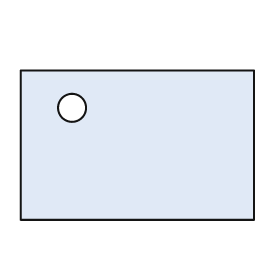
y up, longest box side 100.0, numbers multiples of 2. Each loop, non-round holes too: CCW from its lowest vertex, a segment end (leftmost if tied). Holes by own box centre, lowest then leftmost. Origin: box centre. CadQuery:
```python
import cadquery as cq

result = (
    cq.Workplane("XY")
    .moveTo(-50.0, -32.0)
    .lineTo(50.0, -32.0)
    .lineTo(50.0, 32.0)
    .lineTo(-50.0, 32.0)
    .close()
    .moveTo(-28.0, 16.0)
    .circle(6.0)
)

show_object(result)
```